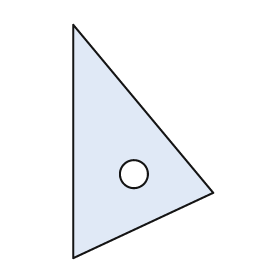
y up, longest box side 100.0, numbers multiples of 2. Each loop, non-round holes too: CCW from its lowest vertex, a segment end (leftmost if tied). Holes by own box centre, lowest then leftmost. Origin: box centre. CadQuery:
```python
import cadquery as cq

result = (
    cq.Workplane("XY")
    .moveTo(-30.0, -50.0)
    .lineTo(30.0, -22.0)
    .lineTo(-30.0, 50.0)
    .close()
    .moveTo(-4.0, -14.0)
    .circle(6.0)
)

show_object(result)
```